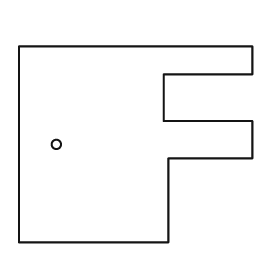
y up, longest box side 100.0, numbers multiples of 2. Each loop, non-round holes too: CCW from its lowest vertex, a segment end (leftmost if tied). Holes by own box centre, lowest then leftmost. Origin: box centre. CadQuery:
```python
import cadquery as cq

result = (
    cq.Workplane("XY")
    .moveTo(-50.0, -42.0)
    .lineTo(14.0, -42.0)
    .lineTo(14.0, -6.0)
    .lineTo(50.0, -6.0)
    .lineTo(50.0, 10.0)
    .lineTo(12.0, 10.0)
    .lineTo(12.0, 30.0)
    .lineTo(50.0, 30.0)
    .lineTo(50.0, 42.0)
    .lineTo(-50.0, 42.0)
    .close()
    .moveTo(-34.0, 0.0)
    .circle(2.0)
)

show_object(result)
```